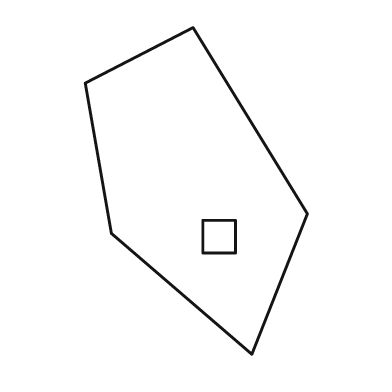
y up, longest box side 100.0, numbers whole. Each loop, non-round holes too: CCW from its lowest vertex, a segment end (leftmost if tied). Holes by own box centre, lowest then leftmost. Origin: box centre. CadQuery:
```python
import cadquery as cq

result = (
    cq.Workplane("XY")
    .moveTo(17.0, -50.0)
    .lineTo(34.0, -7.0)
    .lineTo(-1.0, 50.0)
    .lineTo(-34.0, 33.0)
    .lineTo(-26.0, -13.0)
    .close()
    .moveTo(2.0, -19.0)
    .lineTo(12.0, -19.0)
    .lineTo(12.0, -9.0)
    .lineTo(2.0, -9.0)
    .close()
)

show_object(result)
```